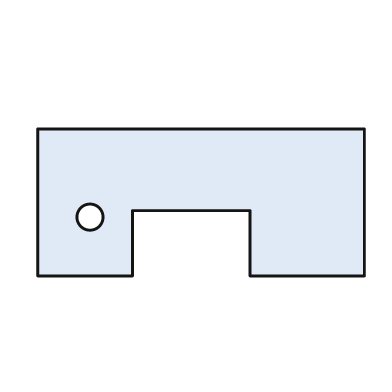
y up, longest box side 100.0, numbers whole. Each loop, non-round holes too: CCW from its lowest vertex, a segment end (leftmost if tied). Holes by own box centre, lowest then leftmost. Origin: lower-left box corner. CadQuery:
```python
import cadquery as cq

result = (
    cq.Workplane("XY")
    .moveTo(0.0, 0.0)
    .lineTo(29.0, 0.0)
    .lineTo(29.0, 20.0)
    .lineTo(65.0, 20.0)
    .lineTo(65.0, 0.0)
    .lineTo(100.0, 0.0)
    .lineTo(100.0, 45.0)
    .lineTo(0.0, 45.0)
    .close()
    .moveTo(16.0, 18.0)
    .circle(4.0)
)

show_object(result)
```